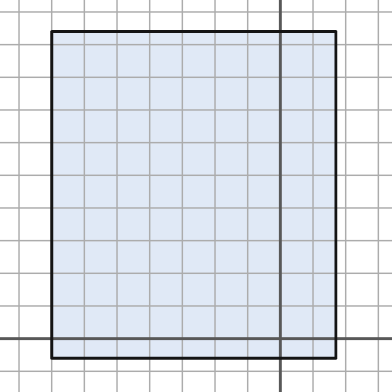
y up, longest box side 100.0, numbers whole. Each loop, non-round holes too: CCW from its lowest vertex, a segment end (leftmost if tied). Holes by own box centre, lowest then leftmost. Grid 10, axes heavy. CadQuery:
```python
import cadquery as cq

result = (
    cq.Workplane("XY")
    .moveTo(-70.0, -6.0)
    .lineTo(17.0, -6.0)
    .lineTo(17.0, 94.0)
    .lineTo(-70.0, 94.0)
    .close()
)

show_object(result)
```